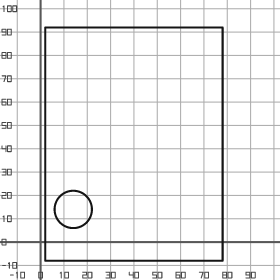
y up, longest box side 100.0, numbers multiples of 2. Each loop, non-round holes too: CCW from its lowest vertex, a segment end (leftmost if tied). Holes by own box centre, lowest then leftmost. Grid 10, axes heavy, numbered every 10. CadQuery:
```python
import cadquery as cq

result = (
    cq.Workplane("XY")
    .moveTo(2.0, -8.0)
    .lineTo(78.0, -8.0)
    .lineTo(78.0, 92.0)
    .lineTo(2.0, 92.0)
    .close()
    .moveTo(14.0, 14.0)
    .circle(8.0)
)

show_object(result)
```